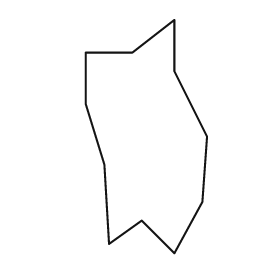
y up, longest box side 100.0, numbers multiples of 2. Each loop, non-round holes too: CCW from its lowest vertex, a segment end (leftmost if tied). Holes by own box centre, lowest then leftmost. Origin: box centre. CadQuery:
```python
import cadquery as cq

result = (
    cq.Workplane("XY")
    .moveTo(12.0, -50.0)
    .lineTo(24.0, -28.0)
    .lineTo(26.0, 0.0)
    .lineTo(12.0, 28.0)
    .lineTo(12.0, 50.0)
    .lineTo(-6.0, 36.0)
    .lineTo(-26.0, 36.0)
    .lineTo(-26.0, 14.0)
    .lineTo(-18.0, -12.0)
    .lineTo(-16.0, -46.0)
    .lineTo(-2.0, -36.0)
    .close()
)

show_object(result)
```